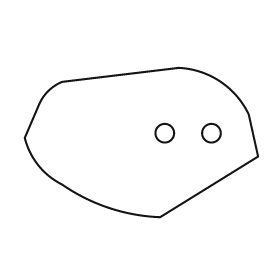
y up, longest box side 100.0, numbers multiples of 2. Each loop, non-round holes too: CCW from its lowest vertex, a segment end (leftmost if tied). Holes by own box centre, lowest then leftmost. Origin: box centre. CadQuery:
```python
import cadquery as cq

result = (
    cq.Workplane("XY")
    .moveTo(8.0, -32.0)
    .lineTo(50.0, -6.0)
    .lineTo(46.0, 12.0)
    .threePointArc((34.0, 26.0), (16.0, 32.0))
    .lineTo(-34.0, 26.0)
    .threePointArc((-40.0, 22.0), (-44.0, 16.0))
    .lineTo(-50.0, 2.0)
    .threePointArc((-44.0, -10.0), (-34.0, -18.0))
    .threePointArc((-14.0, -28.0), (8.0, -32.0))
    .close()
    .moveTo(10.0, 4.0)
    .circle(4.0)
    .moveTo(30.0, 4.0)
    .circle(4.0)
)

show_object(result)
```